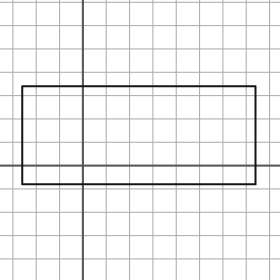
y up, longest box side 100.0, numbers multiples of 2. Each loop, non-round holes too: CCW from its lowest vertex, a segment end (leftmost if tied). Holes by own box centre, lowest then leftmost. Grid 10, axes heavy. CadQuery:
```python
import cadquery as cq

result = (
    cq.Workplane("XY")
    .moveTo(-26.0, -8.0)
    .lineTo(74.0, -8.0)
    .lineTo(74.0, 34.0)
    .lineTo(-26.0, 34.0)
    .close()
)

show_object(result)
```